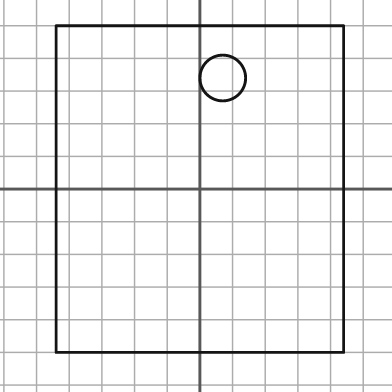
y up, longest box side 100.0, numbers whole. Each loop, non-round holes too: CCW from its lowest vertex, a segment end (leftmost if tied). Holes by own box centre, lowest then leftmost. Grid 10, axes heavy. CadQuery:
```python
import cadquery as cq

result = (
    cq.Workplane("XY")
    .moveTo(-44.0, -50.0)
    .lineTo(44.0, -50.0)
    .lineTo(44.0, 50.0)
    .lineTo(-44.0, 50.0)
    .close()
    .moveTo(7.0, 34.0)
    .circle(7.0)
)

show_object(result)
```